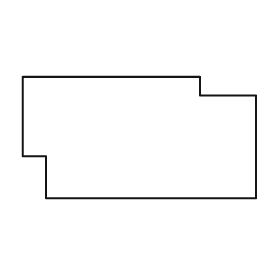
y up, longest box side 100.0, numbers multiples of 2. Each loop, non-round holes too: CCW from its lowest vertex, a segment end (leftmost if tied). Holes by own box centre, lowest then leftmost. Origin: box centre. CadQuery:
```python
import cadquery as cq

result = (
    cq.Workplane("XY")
    .moveTo(-40.0, -26.0)
    .lineTo(50.0, -26.0)
    .lineTo(50.0, 18.0)
    .lineTo(26.0, 18.0)
    .lineTo(26.0, 26.0)
    .lineTo(-50.0, 26.0)
    .lineTo(-50.0, -8.0)
    .lineTo(-40.0, -8.0)
    .close()
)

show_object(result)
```